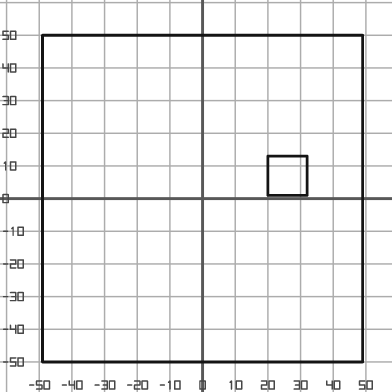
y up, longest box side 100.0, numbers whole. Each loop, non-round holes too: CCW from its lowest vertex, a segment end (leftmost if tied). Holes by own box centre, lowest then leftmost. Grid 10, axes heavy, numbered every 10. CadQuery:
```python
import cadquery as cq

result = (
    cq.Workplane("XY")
    .moveTo(-49.0, -50.0)
    .lineTo(49.0, -50.0)
    .lineTo(49.0, 50.0)
    .lineTo(-49.0, 50.0)
    .close()
    .moveTo(20.0, 1.0)
    .lineTo(32.0, 1.0)
    .lineTo(32.0, 13.0)
    .lineTo(20.0, 13.0)
    .close()
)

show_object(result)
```